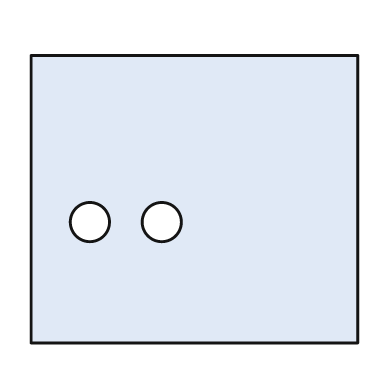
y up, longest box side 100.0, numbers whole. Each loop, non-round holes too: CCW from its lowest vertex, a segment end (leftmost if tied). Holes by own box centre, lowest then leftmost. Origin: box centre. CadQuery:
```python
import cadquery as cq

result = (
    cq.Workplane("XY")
    .moveTo(-50.0, -44.0)
    .lineTo(50.0, -44.0)
    .lineTo(50.0, 44.0)
    .lineTo(-50.0, 44.0)
    .close()
    .moveTo(-32.0, -7.0)
    .circle(6.0)
    .moveTo(-10.0, -7.0)
    .circle(6.0)
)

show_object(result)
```